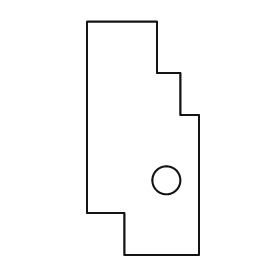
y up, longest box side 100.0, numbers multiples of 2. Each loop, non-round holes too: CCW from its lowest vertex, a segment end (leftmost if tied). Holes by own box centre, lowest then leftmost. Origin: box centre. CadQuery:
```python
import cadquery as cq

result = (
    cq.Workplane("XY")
    .moveTo(-8.0, -50.0)
    .lineTo(24.0, -50.0)
    .lineTo(24.0, 10.0)
    .lineTo(16.0, 10.0)
    .lineTo(16.0, 28.0)
    .lineTo(6.0, 28.0)
    .lineTo(6.0, 50.0)
    .lineTo(-24.0, 50.0)
    .lineTo(-24.0, -32.0)
    .lineTo(-8.0, -32.0)
    .close()
    .moveTo(10.0, -18.0)
    .circle(6.0)
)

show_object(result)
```